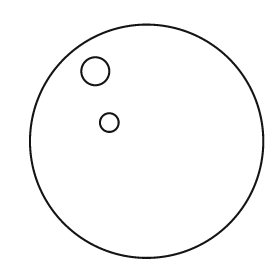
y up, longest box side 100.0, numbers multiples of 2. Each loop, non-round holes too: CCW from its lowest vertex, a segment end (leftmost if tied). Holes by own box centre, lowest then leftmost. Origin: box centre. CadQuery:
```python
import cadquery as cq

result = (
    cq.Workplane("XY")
    .moveTo(0.0, 0.0)
    .circle(50.0)
    .moveTo(-16.0, 8.0)
    .circle(4.0)
    .moveTo(-22.0, 30.0)
    .circle(6.0)
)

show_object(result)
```